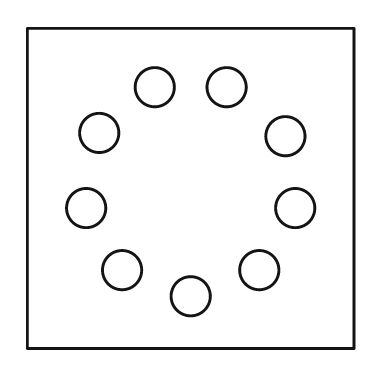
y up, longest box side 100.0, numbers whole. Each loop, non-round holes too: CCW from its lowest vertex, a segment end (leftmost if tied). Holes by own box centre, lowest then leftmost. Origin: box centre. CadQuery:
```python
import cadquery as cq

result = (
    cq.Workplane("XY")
    .moveTo(-50.0, -49.0)
    .lineTo(50.0, -49.0)
    .lineTo(50.0, 49.0)
    .lineTo(-50.0, 49.0)
    .close()
    .moveTo(0.0, -33.0)
    .circle(6.0)
    .moveTo(-21.0, -25.0)
    .circle(6.0)
    .moveTo(21.0, -25.0)
    .circle(6.0)
    .moveTo(-32.0, -6.0)
    .circle(6.0)
    .moveTo(32.0, -6.0)
    .circle(6.0)
    .moveTo(29.0, 16.0)
    .circle(6.0)
    .moveTo(-28.0, 17.0)
    .circle(6.0)
    .moveTo(-11.0, 31.0)
    .circle(6.0)
    .moveTo(11.0, 31.0)
    .circle(6.0)
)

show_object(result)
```